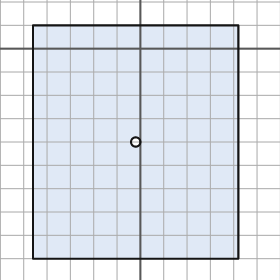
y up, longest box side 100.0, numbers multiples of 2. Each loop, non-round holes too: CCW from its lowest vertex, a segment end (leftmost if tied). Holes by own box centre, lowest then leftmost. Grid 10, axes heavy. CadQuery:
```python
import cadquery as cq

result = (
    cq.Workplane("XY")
    .moveTo(-46.0, -90.0)
    .lineTo(42.0, -90.0)
    .lineTo(42.0, 10.0)
    .lineTo(-46.0, 10.0)
    .close()
    .moveTo(-2.0, -40.0)
    .circle(2.0)
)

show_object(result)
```